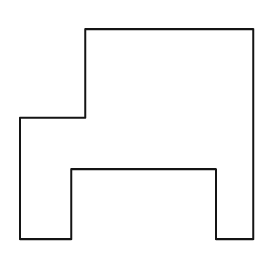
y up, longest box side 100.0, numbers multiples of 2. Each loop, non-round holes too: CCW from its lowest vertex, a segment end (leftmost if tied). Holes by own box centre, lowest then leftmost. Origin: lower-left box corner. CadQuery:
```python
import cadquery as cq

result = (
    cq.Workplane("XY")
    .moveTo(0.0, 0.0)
    .lineTo(22.0, 0.0)
    .lineTo(22.0, 30.0)
    .lineTo(84.0, 30.0)
    .lineTo(84.0, 0.0)
    .lineTo(100.0, 0.0)
    .lineTo(100.0, 90.0)
    .lineTo(28.0, 90.0)
    .lineTo(28.0, 52.0)
    .lineTo(0.0, 52.0)
    .close()
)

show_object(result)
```